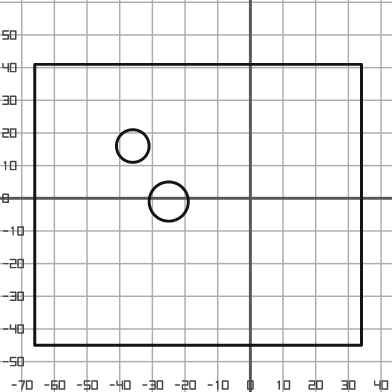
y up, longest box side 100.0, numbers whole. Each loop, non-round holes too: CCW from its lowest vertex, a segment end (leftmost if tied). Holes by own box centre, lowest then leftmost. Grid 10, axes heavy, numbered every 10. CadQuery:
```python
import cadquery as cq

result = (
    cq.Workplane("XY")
    .moveTo(-66.0, -45.0)
    .lineTo(34.0, -45.0)
    .lineTo(34.0, 41.0)
    .lineTo(-66.0, 41.0)
    .close()
    .moveTo(-25.0, -1.0)
    .circle(6.0)
    .moveTo(-36.0, 16.0)
    .circle(5.0)
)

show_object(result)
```